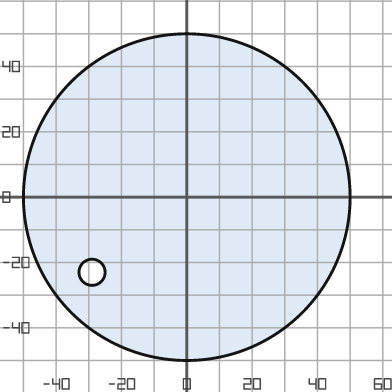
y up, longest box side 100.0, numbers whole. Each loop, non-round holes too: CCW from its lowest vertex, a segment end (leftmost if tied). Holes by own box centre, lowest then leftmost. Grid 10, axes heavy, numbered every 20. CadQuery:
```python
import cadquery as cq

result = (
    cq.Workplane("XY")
    .moveTo(0.0, 0.0)
    .circle(50.0)
    .moveTo(-29.0, -23.0)
    .circle(4.0)
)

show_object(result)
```